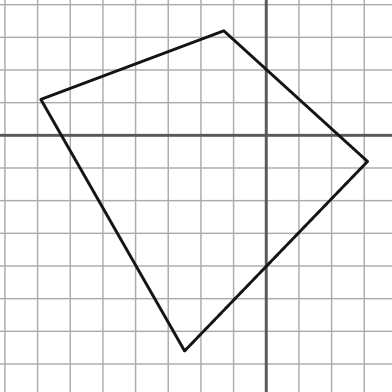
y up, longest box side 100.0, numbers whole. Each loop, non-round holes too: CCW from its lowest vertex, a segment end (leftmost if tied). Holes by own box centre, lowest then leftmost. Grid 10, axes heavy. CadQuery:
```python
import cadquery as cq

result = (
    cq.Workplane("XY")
    .moveTo(-25.0, -66.0)
    .lineTo(31.0, -8.0)
    .lineTo(-13.0, 32.0)
    .lineTo(-69.0, 11.0)
    .close()
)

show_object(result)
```